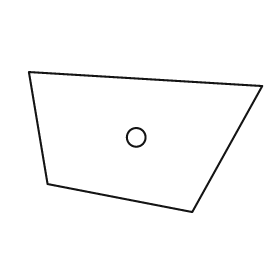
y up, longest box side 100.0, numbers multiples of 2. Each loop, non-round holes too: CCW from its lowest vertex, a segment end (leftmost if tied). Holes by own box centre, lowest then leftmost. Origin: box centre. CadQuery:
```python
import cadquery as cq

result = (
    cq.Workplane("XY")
    .moveTo(20.0, -30.0)
    .lineTo(50.0, 24.0)
    .lineTo(-50.0, 30.0)
    .lineTo(-42.0, -18.0)
    .close()
    .moveTo(-4.0, 2.0)
    .circle(4.0)
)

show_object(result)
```